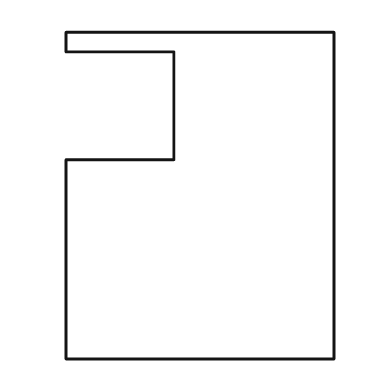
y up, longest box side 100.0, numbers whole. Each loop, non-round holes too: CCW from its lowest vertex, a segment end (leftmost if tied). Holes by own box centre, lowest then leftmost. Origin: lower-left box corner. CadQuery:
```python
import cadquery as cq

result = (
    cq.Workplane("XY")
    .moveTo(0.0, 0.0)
    .lineTo(82.0, 0.0)
    .lineTo(82.0, 100.0)
    .lineTo(0.0, 100.0)
    .lineTo(0.0, 94.0)
    .lineTo(33.0, 94.0)
    .lineTo(33.0, 61.0)
    .lineTo(0.0, 61.0)
    .close()
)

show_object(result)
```